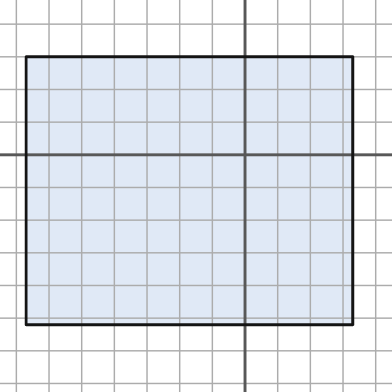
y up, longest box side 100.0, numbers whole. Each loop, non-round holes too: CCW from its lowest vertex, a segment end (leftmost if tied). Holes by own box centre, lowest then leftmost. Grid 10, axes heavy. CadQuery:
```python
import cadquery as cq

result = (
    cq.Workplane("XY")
    .moveTo(-67.0, -52.0)
    .lineTo(33.0, -52.0)
    .lineTo(33.0, 30.0)
    .lineTo(-67.0, 30.0)
    .close()
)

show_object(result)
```